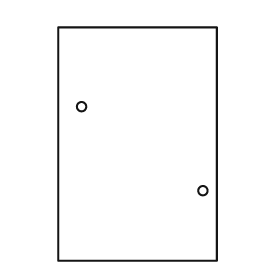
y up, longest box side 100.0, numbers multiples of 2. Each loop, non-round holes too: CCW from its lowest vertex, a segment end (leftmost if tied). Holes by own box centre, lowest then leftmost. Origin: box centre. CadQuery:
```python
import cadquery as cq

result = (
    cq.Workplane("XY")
    .moveTo(-34.0, -50.0)
    .lineTo(34.0, -50.0)
    .lineTo(34.0, 50.0)
    .lineTo(-34.0, 50.0)
    .close()
    .moveTo(28.0, -20.0)
    .circle(2.0)
    .moveTo(-24.0, 16.0)
    .circle(2.0)
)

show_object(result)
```